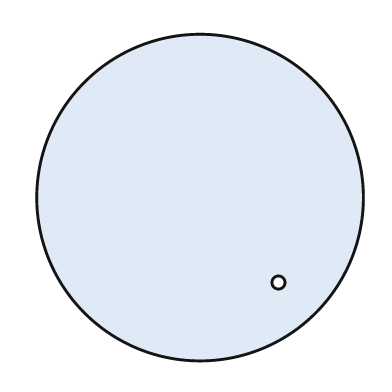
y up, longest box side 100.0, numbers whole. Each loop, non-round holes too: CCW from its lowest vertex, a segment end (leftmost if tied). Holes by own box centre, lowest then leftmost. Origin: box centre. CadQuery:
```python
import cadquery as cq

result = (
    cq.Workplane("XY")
    .moveTo(0.0, 0.0)
    .circle(50.0)
    .moveTo(24.0, -26.0)
    .circle(2.0)
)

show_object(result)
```